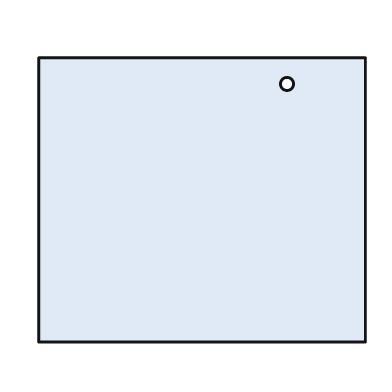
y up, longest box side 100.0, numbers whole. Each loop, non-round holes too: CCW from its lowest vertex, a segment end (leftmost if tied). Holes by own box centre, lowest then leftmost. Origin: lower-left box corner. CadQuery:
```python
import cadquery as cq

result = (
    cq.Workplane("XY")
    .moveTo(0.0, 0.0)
    .lineTo(100.0, 0.0)
    .lineTo(100.0, 87.0)
    .lineTo(0.0, 87.0)
    .close()
    .moveTo(76.0, 79.0)
    .circle(2.0)
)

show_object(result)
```